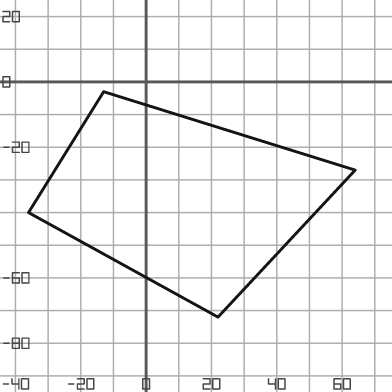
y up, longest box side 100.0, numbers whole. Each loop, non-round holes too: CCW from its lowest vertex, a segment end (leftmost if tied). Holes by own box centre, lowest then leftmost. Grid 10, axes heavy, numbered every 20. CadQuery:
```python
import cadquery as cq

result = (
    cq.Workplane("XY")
    .moveTo(22.0, -72.0)
    .lineTo(64.0, -27.0)
    .lineTo(-13.0, -3.0)
    .lineTo(-36.0, -40.0)
    .close()
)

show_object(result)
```